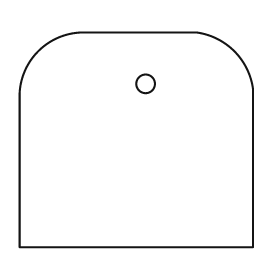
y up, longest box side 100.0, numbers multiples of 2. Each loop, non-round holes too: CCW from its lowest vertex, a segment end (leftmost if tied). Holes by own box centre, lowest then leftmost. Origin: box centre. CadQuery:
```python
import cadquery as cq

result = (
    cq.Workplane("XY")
    .moveTo(-50.0, -46.0)
    .lineTo(50.0, -46.0)
    .lineTo(50.0, 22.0)
    .threePointArc((42.0, 38.0), (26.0, 46.0))
    .lineTo(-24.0, 46.0)
    .threePointArc((-42.0, 38.0), (-50.0, 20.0))
    .close()
    .moveTo(4.0, 24.0)
    .circle(4.0)
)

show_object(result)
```